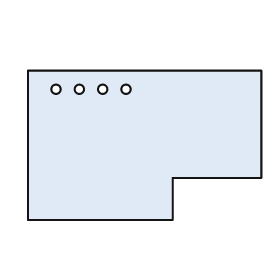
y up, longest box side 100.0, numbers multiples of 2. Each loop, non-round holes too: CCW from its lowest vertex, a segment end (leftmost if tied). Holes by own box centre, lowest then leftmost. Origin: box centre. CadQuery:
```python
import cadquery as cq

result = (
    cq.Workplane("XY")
    .moveTo(-50.0, -32.0)
    .lineTo(12.0, -32.0)
    .lineTo(12.0, -14.0)
    .lineTo(50.0, -14.0)
    .lineTo(50.0, 32.0)
    .lineTo(-50.0, 32.0)
    .close()
    .moveTo(-38.0, 24.0)
    .circle(2.0)
    .moveTo(-28.0, 24.0)
    .circle(2.0)
    .moveTo(-18.0, 24.0)
    .circle(2.0)
    .moveTo(-8.0, 24.0)
    .circle(2.0)
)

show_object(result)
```